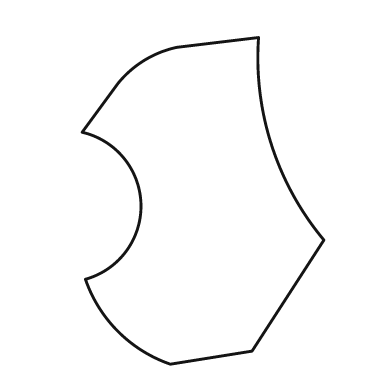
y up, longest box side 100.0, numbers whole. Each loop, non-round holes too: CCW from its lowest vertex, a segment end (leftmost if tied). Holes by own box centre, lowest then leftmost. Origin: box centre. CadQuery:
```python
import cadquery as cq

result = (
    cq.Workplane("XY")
    .moveTo(-10.0, -50.0)
    .lineTo(15.0, -46.0)
    .lineTo(37.0, -12.0)
    .threePointArc((21.0, 17.0), (17.0, 50.0))
    .lineTo(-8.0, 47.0)
    .threePointArc((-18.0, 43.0), (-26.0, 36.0))
    .lineTo(-37.0, 21.0)
    .threePointArc((-19.0, -1.0), (-36.0, -24.0))
    .threePointArc((-26.0, -40.0), (-10.0, -50.0))
    .close()
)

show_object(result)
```